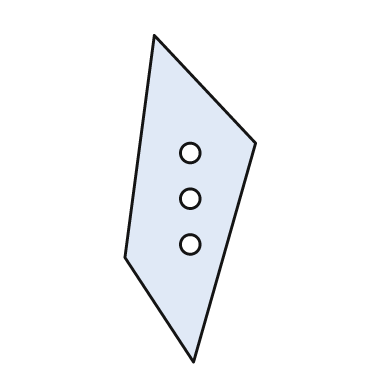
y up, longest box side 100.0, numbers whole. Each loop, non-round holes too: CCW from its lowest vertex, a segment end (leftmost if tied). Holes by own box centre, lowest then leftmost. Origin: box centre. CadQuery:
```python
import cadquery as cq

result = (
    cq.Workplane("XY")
    .moveTo(1.0, -50.0)
    .lineTo(20.0, 17.0)
    .lineTo(-11.0, 50.0)
    .lineTo(-20.0, -18.0)
    .close()
    .moveTo(0.0, -14.0)
    .circle(3.0)
    .moveTo(0.0, 0.0)
    .circle(3.0)
    .moveTo(0.0, 14.0)
    .circle(3.0)
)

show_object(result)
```